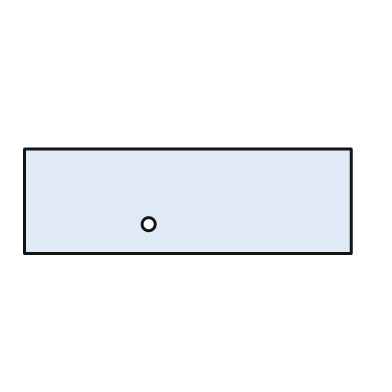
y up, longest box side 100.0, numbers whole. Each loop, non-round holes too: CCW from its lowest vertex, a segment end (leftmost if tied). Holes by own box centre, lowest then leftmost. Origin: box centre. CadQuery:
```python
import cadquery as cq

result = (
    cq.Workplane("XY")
    .moveTo(-50.0, -16.0)
    .lineTo(50.0, -16.0)
    .lineTo(50.0, 16.0)
    .lineTo(-50.0, 16.0)
    .close()
    .moveTo(-12.0, -7.0)
    .circle(2.0)
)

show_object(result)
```